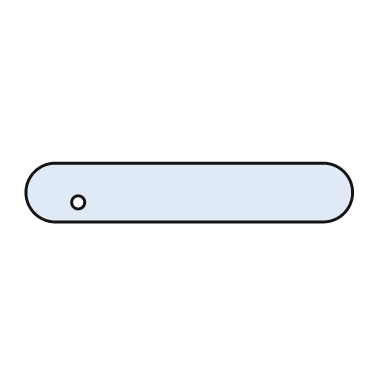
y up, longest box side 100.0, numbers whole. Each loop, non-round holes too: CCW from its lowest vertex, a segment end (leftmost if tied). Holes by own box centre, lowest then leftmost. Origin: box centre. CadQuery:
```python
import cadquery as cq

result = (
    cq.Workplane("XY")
    .moveTo(-41.0, -9.0)
    .lineTo(41.0, -9.0)
    .threePointArc((50.0, 0.0), (41.0, 9.0))
    .lineTo(-41.0, 9.0)
    .threePointArc((-50.0, 0.0), (-41.0, -9.0))
    .close()
    .moveTo(-34.0, -3.0)
    .circle(2.0)
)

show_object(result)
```